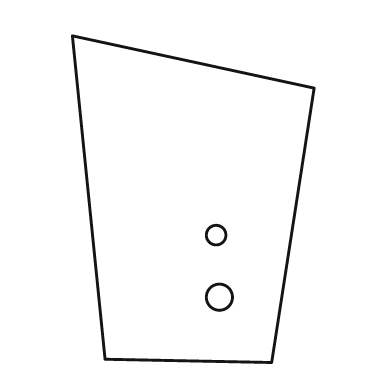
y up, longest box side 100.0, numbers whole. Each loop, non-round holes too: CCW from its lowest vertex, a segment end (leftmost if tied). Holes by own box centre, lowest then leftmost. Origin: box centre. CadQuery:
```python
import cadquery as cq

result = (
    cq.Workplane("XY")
    .moveTo(24.0, -50.0)
    .lineTo(37.0, 34.0)
    .lineTo(-37.0, 50.0)
    .lineTo(-27.0, -49.0)
    .close()
    .moveTo(8.0, -30.0)
    .circle(4.0)
    .moveTo(7.0, -11.0)
    .circle(3.0)
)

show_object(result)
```